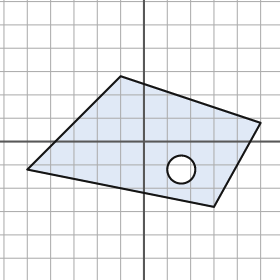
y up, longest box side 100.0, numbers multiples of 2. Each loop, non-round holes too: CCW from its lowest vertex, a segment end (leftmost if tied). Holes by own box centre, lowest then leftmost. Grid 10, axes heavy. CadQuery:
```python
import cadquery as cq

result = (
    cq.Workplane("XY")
    .moveTo(30.0, -28.0)
    .lineTo(50.0, 8.0)
    .lineTo(-10.0, 28.0)
    .lineTo(-50.0, -12.0)
    .close()
    .moveTo(16.0, -12.0)
    .circle(6.0)
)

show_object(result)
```